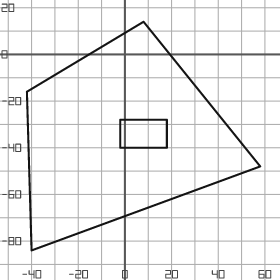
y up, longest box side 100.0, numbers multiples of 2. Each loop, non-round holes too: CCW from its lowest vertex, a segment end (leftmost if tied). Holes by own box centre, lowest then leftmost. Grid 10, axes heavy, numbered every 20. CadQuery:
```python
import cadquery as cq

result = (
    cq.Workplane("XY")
    .moveTo(-40.0, -84.0)
    .lineTo(58.0, -48.0)
    .lineTo(8.0, 14.0)
    .lineTo(-42.0, -16.0)
    .close()
    .moveTo(-2.0, -40.0)
    .lineTo(18.0, -40.0)
    .lineTo(18.0, -28.0)
    .lineTo(-2.0, -28.0)
    .close()
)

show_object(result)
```